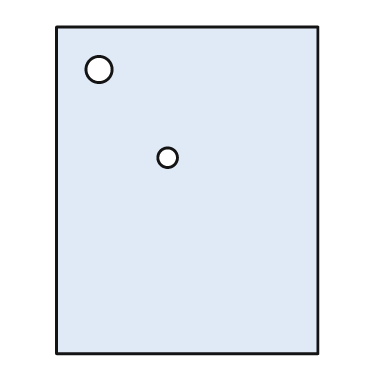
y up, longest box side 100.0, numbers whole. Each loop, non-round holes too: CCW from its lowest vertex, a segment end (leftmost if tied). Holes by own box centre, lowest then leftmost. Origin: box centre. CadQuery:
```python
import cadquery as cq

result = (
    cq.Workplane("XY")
    .moveTo(-40.0, -50.0)
    .lineTo(40.0, -50.0)
    .lineTo(40.0, 50.0)
    .lineTo(-40.0, 50.0)
    .close()
    .moveTo(-6.0, 10.0)
    .circle(3.0)
    .moveTo(-27.0, 37.0)
    .circle(4.0)
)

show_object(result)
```